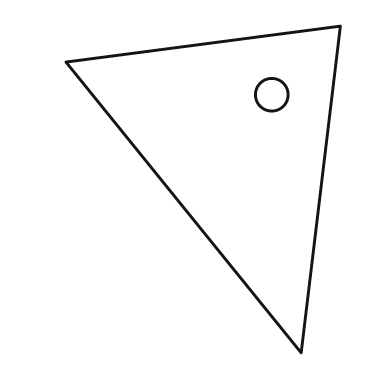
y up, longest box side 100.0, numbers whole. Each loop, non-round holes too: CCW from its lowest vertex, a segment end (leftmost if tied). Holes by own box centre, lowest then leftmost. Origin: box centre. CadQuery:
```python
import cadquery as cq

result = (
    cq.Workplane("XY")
    .moveTo(30.0, -50.0)
    .lineTo(42.0, 50.0)
    .lineTo(-42.0, 39.0)
    .close()
    .moveTo(21.0, 29.0)
    .circle(5.0)
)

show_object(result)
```